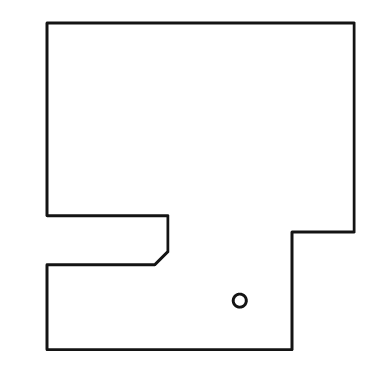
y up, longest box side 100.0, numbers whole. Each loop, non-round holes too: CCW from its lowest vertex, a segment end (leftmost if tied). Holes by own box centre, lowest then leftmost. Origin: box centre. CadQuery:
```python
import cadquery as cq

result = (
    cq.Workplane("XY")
    .moveTo(-47.0, -50.0)
    .lineTo(28.0, -50.0)
    .lineTo(28.0, -14.0)
    .lineTo(47.0, -14.0)
    .lineTo(47.0, 50.0)
    .lineTo(-47.0, 50.0)
    .lineTo(-47.0, -9.0)
    .lineTo(-10.0, -9.0)
    .lineTo(-10.0, -20.0)
    .lineTo(-14.0, -24.0)
    .lineTo(-47.0, -24.0)
    .close()
    .moveTo(12.0, -35.0)
    .circle(2.0)
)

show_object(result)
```